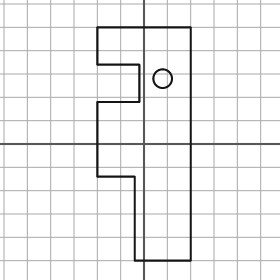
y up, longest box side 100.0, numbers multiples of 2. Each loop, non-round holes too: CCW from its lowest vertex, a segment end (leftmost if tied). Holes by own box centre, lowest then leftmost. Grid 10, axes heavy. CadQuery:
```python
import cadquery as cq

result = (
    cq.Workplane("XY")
    .moveTo(-4.0, -50.0)
    .lineTo(20.0, -50.0)
    .lineTo(20.0, 50.0)
    .lineTo(-20.0, 50.0)
    .lineTo(-20.0, 34.0)
    .lineTo(-2.0, 34.0)
    .lineTo(-2.0, 18.0)
    .lineTo(-20.0, 18.0)
    .lineTo(-20.0, -14.0)
    .lineTo(-4.0, -14.0)
    .close()
    .moveTo(8.0, 28.0)
    .circle(4.0)
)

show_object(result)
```